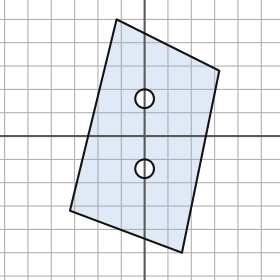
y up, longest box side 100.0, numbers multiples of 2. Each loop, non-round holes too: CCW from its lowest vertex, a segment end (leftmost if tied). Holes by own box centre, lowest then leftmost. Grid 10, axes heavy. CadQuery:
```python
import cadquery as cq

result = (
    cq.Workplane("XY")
    .moveTo(16.0, -50.0)
    .lineTo(32.0, 28.0)
    .lineTo(-12.0, 50.0)
    .lineTo(-32.0, -32.0)
    .close()
    .moveTo(0.0, -14.0)
    .circle(4.0)
    .moveTo(0.0, 16.0)
    .circle(4.0)
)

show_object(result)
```